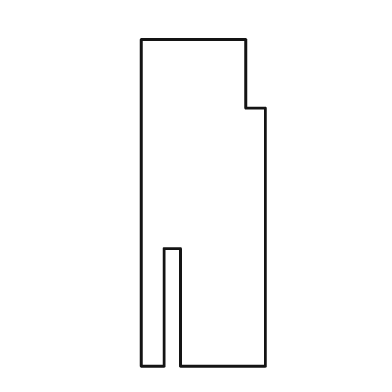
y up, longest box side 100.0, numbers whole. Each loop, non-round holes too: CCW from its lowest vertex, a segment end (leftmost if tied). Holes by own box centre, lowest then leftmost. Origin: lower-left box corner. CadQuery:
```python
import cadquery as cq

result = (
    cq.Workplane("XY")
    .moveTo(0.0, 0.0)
    .lineTo(7.0, 0.0)
    .lineTo(7.0, 36.0)
    .lineTo(12.0, 36.0)
    .lineTo(12.0, 0.0)
    .lineTo(38.0, 0.0)
    .lineTo(38.0, 79.0)
    .lineTo(32.0, 79.0)
    .lineTo(32.0, 100.0)
    .lineTo(0.0, 100.0)
    .close()
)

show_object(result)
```